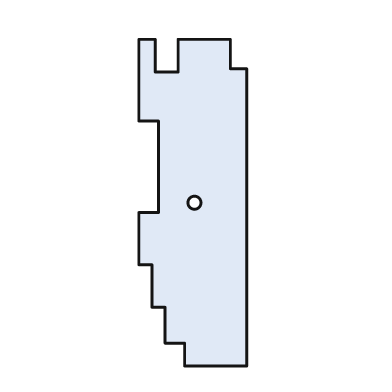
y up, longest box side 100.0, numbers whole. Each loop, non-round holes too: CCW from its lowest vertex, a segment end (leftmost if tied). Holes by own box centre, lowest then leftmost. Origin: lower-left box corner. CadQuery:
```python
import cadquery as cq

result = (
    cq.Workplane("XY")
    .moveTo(14.0, 0.0)
    .lineTo(33.0, 0.0)
    .lineTo(33.0, 91.0)
    .lineTo(28.0, 91.0)
    .lineTo(28.0, 100.0)
    .lineTo(12.0, 100.0)
    .lineTo(12.0, 90.0)
    .lineTo(5.0, 90.0)
    .lineTo(5.0, 100.0)
    .lineTo(0.0, 100.0)
    .lineTo(0.0, 75.0)
    .lineTo(6.0, 75.0)
    .lineTo(6.0, 47.0)
    .lineTo(0.0, 47.0)
    .lineTo(0.0, 31.0)
    .lineTo(4.0, 31.0)
    .lineTo(4.0, 18.0)
    .lineTo(8.0, 18.0)
    .lineTo(8.0, 7.0)
    .lineTo(14.0, 7.0)
    .close()
    .moveTo(17.0, 50.0)
    .circle(2.0)
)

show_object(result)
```